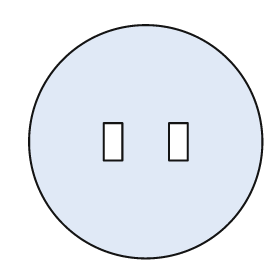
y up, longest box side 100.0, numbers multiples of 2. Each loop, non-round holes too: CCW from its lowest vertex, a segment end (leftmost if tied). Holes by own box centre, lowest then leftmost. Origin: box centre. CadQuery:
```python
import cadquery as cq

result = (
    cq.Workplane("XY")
    .moveTo(0.0, 0.0)
    .circle(50.0)
    .moveTo(-18.0, -8.0)
    .lineTo(-10.0, -8.0)
    .lineTo(-10.0, 8.0)
    .lineTo(-18.0, 8.0)
    .close()
    .moveTo(10.0, -8.0)
    .lineTo(18.0, -8.0)
    .lineTo(18.0, 8.0)
    .lineTo(10.0, 8.0)
    .close()
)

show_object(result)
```